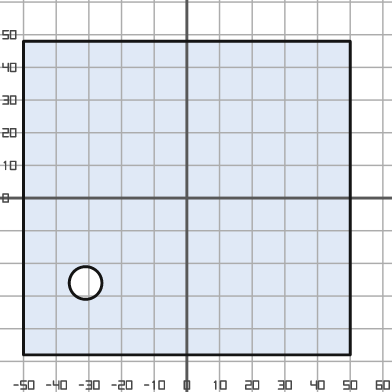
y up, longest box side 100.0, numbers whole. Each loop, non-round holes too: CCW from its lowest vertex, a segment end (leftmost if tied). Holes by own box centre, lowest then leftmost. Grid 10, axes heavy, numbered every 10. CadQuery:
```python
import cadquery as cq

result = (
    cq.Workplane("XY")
    .moveTo(-50.0, -48.0)
    .lineTo(50.0, -48.0)
    .lineTo(50.0, 48.0)
    .lineTo(-50.0, 48.0)
    .close()
    .moveTo(-31.0, -26.0)
    .circle(5.0)
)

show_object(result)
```